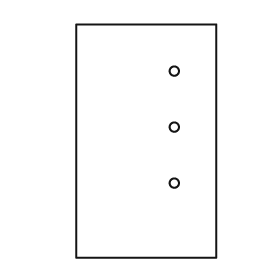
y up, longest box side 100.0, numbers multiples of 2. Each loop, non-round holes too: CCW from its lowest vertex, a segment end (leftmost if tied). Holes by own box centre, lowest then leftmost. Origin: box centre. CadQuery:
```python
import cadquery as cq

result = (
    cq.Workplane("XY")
    .moveTo(-30.0, -50.0)
    .lineTo(30.0, -50.0)
    .lineTo(30.0, 50.0)
    .lineTo(-30.0, 50.0)
    .close()
    .moveTo(12.0, -18.0)
    .circle(2.0)
    .moveTo(12.0, 6.0)
    .circle(2.0)
    .moveTo(12.0, 30.0)
    .circle(2.0)
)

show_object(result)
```